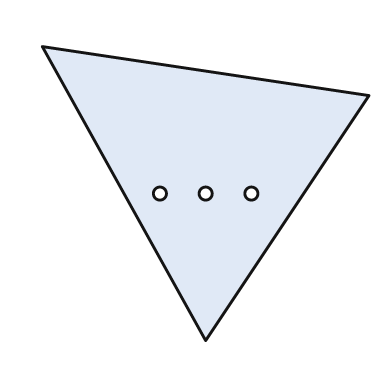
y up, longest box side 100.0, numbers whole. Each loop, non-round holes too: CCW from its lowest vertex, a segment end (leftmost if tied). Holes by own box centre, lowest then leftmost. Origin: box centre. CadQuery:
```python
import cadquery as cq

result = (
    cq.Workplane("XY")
    .moveTo(0.0, -45.0)
    .lineTo(50.0, 30.0)
    .lineTo(-50.0, 45.0)
    .close()
    .moveTo(-14.0, 0.0)
    .circle(2.0)
    .moveTo(0.0, 0.0)
    .circle(2.0)
    .moveTo(14.0, 0.0)
    .circle(2.0)
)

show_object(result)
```